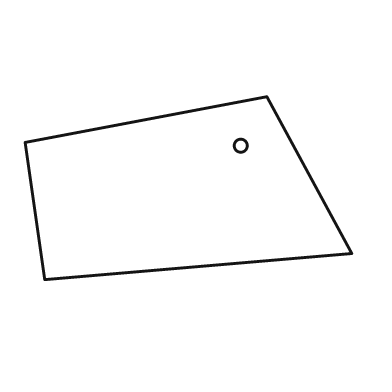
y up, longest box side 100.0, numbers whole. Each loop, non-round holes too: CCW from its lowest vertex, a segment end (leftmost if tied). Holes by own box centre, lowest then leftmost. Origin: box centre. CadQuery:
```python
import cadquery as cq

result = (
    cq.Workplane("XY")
    .moveTo(-44.0, -28.0)
    .lineTo(50.0, -20.0)
    .lineTo(24.0, 28.0)
    .lineTo(-50.0, 14.0)
    .close()
    .moveTo(16.0, 13.0)
    .circle(2.0)
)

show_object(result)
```